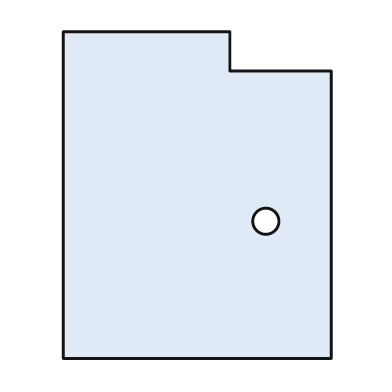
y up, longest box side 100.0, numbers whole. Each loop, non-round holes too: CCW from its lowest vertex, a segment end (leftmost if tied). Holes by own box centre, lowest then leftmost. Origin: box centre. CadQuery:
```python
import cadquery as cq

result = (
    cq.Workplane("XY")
    .moveTo(-41.0, -50.0)
    .lineTo(41.0, -50.0)
    .lineTo(41.0, 38.0)
    .lineTo(10.0, 38.0)
    .lineTo(10.0, 50.0)
    .lineTo(-41.0, 50.0)
    .close()
    .moveTo(21.0, -8.0)
    .circle(4.0)
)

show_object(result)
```